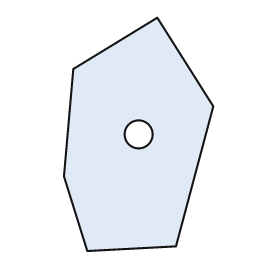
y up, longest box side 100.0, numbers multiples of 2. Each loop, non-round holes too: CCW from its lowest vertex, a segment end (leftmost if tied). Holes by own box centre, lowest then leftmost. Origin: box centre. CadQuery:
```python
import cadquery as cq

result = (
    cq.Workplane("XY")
    .moveTo(-22.0, -50.0)
    .lineTo(16.0, -48.0)
    .lineTo(32.0, 12.0)
    .lineTo(8.0, 50.0)
    .lineTo(-28.0, 28.0)
    .lineTo(-32.0, -18.0)
    .close()
    .moveTo(0.0, 0.0)
    .circle(6.0)
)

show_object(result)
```